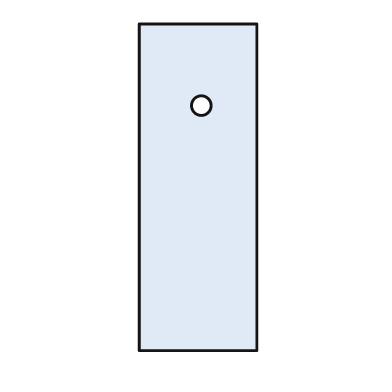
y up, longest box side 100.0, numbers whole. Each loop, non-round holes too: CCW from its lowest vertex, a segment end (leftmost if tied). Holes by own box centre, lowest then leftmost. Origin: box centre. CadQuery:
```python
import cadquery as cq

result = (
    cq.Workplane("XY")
    .moveTo(-18.0, -50.0)
    .lineTo(18.0, -50.0)
    .lineTo(18.0, 50.0)
    .lineTo(-18.0, 50.0)
    .close()
    .moveTo(1.0, 25.0)
    .circle(3.0)
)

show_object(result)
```